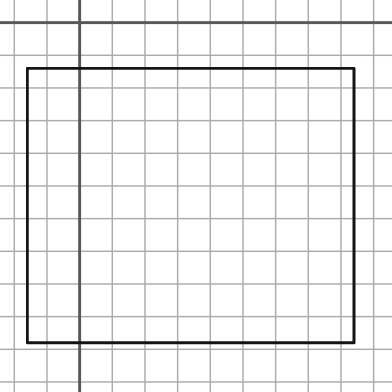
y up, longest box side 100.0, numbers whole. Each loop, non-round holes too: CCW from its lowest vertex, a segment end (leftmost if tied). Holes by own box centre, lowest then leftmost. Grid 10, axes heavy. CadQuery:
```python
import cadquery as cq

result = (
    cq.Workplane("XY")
    .moveTo(-16.0, -98.0)
    .lineTo(84.0, -98.0)
    .lineTo(84.0, -14.0)
    .lineTo(-16.0, -14.0)
    .close()
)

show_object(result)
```